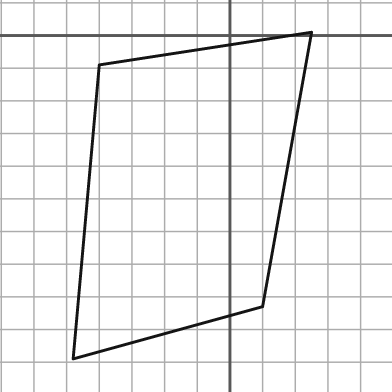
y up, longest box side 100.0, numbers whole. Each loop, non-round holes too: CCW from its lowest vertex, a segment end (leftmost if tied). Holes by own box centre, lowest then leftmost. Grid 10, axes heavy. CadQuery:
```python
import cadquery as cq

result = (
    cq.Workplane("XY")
    .moveTo(-48.0, -99.0)
    .lineTo(10.0, -83.0)
    .lineTo(25.0, 1.0)
    .lineTo(-40.0, -9.0)
    .close()
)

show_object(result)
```